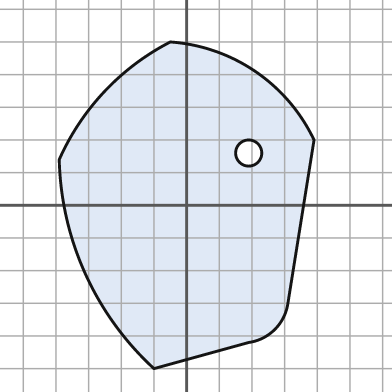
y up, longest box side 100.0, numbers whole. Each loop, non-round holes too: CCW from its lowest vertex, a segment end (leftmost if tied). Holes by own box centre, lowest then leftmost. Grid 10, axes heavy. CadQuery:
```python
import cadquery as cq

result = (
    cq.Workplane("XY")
    .moveTo(-10.0, -50.0)
    .lineTo(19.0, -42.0)
    .threePointArc((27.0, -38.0), (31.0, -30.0))
    .lineTo(39.0, 20.0)
    .threePointArc((21.0, 41.0), (-5.0, 50.0))
    .threePointArc((-25.0, 35.0), (-39.0, 14.0))
    .threePointArc((-31.0, -21.0), (-10.0, -50.0))
    .close()
    .moveTo(19.0, 16.0)
    .circle(4.0)
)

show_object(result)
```